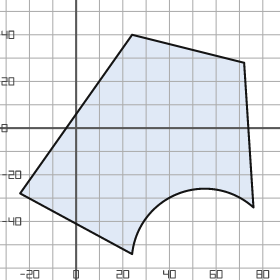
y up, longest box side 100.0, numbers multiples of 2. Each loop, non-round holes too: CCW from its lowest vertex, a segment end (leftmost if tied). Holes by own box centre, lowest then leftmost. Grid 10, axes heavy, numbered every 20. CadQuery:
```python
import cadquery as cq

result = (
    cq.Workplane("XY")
    .moveTo(24.0, -54.0)
    .threePointArc((44.0, -28.0), (76.0, -34.0))
    .lineTo(72.0, 28.0)
    .lineTo(24.0, 40.0)
    .lineTo(-24.0, -28.0)
    .close()
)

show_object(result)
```